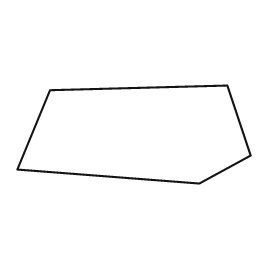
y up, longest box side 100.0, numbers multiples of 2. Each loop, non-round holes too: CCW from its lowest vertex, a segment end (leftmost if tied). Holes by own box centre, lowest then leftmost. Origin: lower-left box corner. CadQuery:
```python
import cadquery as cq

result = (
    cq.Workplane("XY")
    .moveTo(78.0, 0.0)
    .lineTo(100.0, 12.0)
    .lineTo(90.0, 42.0)
    .lineTo(14.0, 40.0)
    .lineTo(0.0, 6.0)
    .close()
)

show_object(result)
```